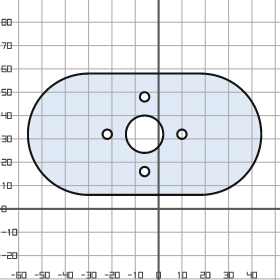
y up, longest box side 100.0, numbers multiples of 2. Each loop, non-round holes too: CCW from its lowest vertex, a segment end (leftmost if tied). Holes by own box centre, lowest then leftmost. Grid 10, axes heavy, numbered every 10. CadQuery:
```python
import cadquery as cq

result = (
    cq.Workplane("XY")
    .moveTo(-30.0, 6.0)
    .lineTo(18.0, 6.0)
    .threePointArc((44.0, 32.0), (18.0, 58.0))
    .lineTo(-30.0, 58.0)
    .threePointArc((-56.0, 32.0), (-30.0, 6.0))
    .close()
    .moveTo(-6.0, 16.0)
    .circle(2.0)
    .moveTo(-22.0, 32.0)
    .circle(2.0)
    .moveTo(-6.0, 32.0)
    .circle(8.0)
    .moveTo(10.0, 32.0)
    .circle(2.0)
    .moveTo(-6.0, 48.0)
    .circle(2.0)
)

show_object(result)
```